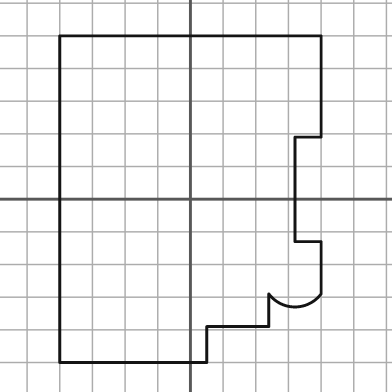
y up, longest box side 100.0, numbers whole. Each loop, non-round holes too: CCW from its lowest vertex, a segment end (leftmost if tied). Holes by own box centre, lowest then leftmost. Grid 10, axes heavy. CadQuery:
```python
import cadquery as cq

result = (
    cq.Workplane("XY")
    .moveTo(-40.0, -50.0)
    .lineTo(5.0, -50.0)
    .lineTo(5.0, -39.0)
    .lineTo(24.0, -39.0)
    .lineTo(24.0, -29.0)
    .threePointArc((32.0, -33.0), (40.0, -29.0))
    .lineTo(40.0, -13.0)
    .lineTo(32.0, -13.0)
    .lineTo(32.0, 19.0)
    .lineTo(40.0, 19.0)
    .lineTo(40.0, 50.0)
    .lineTo(-40.0, 50.0)
    .close()
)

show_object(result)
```